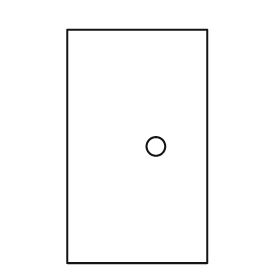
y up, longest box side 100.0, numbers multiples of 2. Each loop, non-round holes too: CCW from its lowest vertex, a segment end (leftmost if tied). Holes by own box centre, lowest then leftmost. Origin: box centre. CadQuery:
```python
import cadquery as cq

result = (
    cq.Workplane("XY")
    .moveTo(-30.0, -50.0)
    .lineTo(30.0, -50.0)
    .lineTo(30.0, 50.0)
    .lineTo(-30.0, 50.0)
    .close()
    .moveTo(8.0, 0.0)
    .circle(4.0)
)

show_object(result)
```